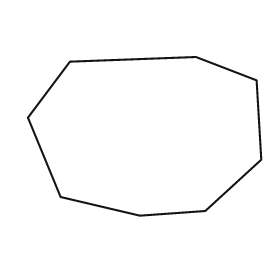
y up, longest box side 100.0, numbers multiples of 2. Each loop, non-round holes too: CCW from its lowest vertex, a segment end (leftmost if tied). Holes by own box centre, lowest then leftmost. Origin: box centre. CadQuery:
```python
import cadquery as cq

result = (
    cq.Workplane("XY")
    .moveTo(-2.0, -34.0)
    .lineTo(26.0, -32.0)
    .lineTo(50.0, -10.0)
    .lineTo(48.0, 24.0)
    .lineTo(22.0, 34.0)
    .lineTo(-32.0, 32.0)
    .lineTo(-50.0, 8.0)
    .lineTo(-36.0, -26.0)
    .close()
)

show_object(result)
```